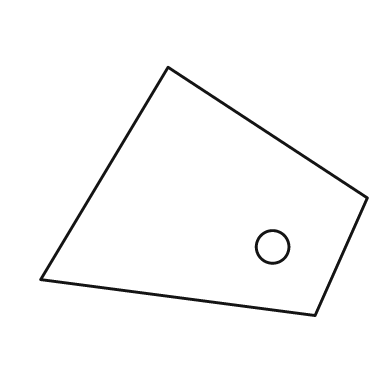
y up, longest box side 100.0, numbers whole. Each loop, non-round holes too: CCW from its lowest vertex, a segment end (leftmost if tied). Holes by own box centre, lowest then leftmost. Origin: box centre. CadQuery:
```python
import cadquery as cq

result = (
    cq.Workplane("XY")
    .moveTo(34.0, -38.0)
    .lineTo(50.0, -2.0)
    .lineTo(-11.0, 38.0)
    .lineTo(-50.0, -27.0)
    .close()
    .moveTo(21.0, -17.0)
    .circle(5.0)
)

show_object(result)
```